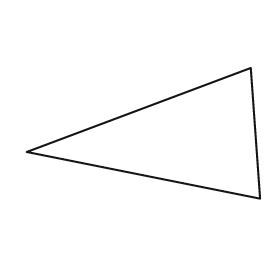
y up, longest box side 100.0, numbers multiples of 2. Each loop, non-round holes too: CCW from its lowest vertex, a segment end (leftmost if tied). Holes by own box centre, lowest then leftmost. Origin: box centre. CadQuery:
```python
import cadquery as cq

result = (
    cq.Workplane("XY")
    .moveTo(50.0, -28.0)
    .lineTo(46.0, 28.0)
    .lineTo(-50.0, -8.0)
    .close()
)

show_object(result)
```